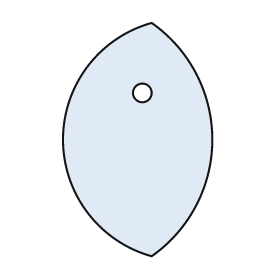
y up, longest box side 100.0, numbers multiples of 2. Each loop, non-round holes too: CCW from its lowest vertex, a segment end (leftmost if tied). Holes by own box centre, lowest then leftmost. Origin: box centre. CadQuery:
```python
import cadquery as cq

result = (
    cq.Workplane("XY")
    .moveTo(6.0, -50.0)
    .threePointArc((32.0, 0.0), (6.0, 50.0))
    .threePointArc((-32.0, 0.0), (6.0, -50.0))
    .close()
    .moveTo(2.0, 20.0)
    .circle(4.0)
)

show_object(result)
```